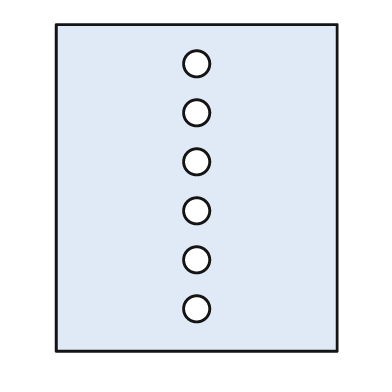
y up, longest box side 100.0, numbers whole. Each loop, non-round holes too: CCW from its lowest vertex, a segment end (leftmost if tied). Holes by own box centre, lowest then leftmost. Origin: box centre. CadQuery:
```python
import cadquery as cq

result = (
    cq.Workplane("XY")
    .moveTo(-43.0, -50.0)
    .lineTo(43.0, -50.0)
    .lineTo(43.0, 50.0)
    .lineTo(-43.0, 50.0)
    .close()
    .moveTo(0.0, -37.0)
    .circle(4.0)
    .moveTo(0.0, -22.0)
    .circle(4.0)
    .moveTo(0.0, -7.0)
    .circle(4.0)
    .moveTo(0.0, 8.0)
    .circle(4.0)
    .moveTo(0.0, 23.0)
    .circle(4.0)
    .moveTo(0.0, 38.0)
    .circle(4.0)
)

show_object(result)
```